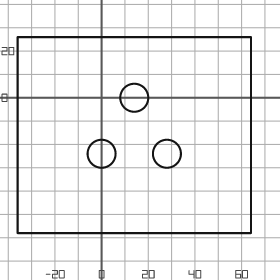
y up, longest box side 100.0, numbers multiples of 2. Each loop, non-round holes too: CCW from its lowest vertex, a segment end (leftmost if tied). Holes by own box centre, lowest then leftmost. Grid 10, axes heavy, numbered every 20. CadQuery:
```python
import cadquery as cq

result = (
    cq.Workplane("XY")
    .moveTo(-36.0, -58.0)
    .lineTo(64.0, -58.0)
    .lineTo(64.0, 26.0)
    .lineTo(-36.0, 26.0)
    .close()
    .moveTo(0.0, -24.0)
    .circle(6.0)
    .moveTo(28.0, -24.0)
    .circle(6.0)
    .moveTo(14.0, 0.0)
    .circle(6.0)
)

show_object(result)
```